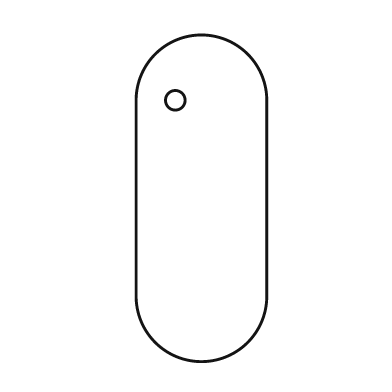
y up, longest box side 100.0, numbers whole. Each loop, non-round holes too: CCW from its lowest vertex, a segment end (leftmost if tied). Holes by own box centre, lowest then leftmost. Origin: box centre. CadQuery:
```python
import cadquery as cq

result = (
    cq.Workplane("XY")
    .moveTo(-20.0, -30.0)
    .threePointArc((0.0, -50.0), (20.0, -30.0))
    .lineTo(20.0, 30.0)
    .threePointArc((0.0, 50.0), (-20.0, 30.0))
    .close()
    .moveTo(-8.0, 30.0)
    .circle(3.0)
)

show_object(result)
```